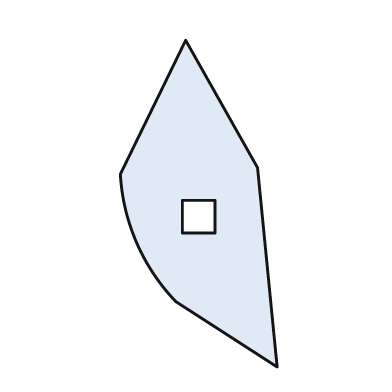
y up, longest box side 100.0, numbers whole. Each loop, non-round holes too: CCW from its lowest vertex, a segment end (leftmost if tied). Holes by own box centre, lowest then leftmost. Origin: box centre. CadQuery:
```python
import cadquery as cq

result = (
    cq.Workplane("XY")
    .moveTo(24.0, -50.0)
    .lineTo(18.0, 11.0)
    .lineTo(-4.0, 50.0)
    .lineTo(-24.0, 9.0)
    .threePointArc((-19.0, -12.0), (-7.0, -30.0))
    .close()
    .moveTo(-5.0, -9.0)
    .lineTo(5.0, -9.0)
    .lineTo(5.0, 1.0)
    .lineTo(-5.0, 1.0)
    .close()
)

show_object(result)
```